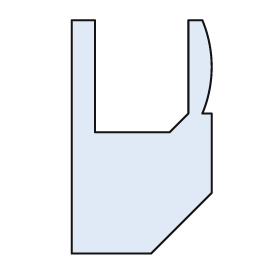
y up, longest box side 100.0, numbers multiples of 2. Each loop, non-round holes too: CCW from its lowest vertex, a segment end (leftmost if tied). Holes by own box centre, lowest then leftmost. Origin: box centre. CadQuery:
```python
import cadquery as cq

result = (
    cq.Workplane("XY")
    .moveTo(-30.0, -50.0)
    .lineTo(4.0, -50.0)
    .lineTo(30.0, -24.0)
    .lineTo(30.0, 10.0)
    .lineTo(26.0, 10.0)
    .threePointArc((30.0, 30.0), (26.0, 50.0))
    .lineTo(20.0, 50.0)
    .lineTo(20.0, 10.0)
    .lineTo(12.0, 2.0)
    .lineTo(-20.0, 2.0)
    .lineTo(-20.0, 50.0)
    .lineTo(-30.0, 50.0)
    .close()
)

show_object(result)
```